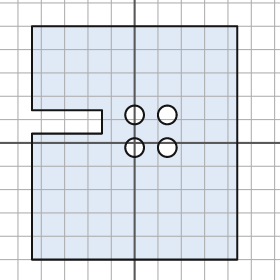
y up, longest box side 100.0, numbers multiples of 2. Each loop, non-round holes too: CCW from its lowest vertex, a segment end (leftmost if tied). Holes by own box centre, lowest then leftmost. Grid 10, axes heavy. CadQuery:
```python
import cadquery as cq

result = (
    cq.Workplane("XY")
    .moveTo(-44.0, -50.0)
    .lineTo(44.0, -50.0)
    .lineTo(44.0, 50.0)
    .lineTo(-44.0, 50.0)
    .lineTo(-44.0, 14.0)
    .lineTo(-14.0, 14.0)
    .lineTo(-14.0, 4.0)
    .lineTo(-44.0, 4.0)
    .close()
    .moveTo(0.0, -2.0)
    .circle(4.0)
    .moveTo(14.0, -2.0)
    .circle(4.0)
    .moveTo(0.0, 12.0)
    .circle(4.0)
    .moveTo(14.0, 12.0)
    .circle(4.0)
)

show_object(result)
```